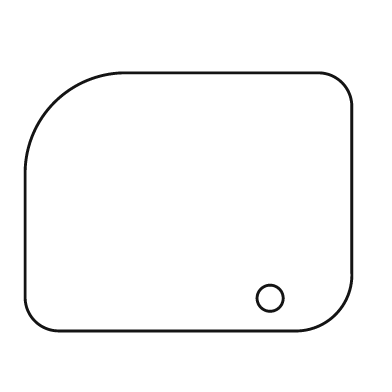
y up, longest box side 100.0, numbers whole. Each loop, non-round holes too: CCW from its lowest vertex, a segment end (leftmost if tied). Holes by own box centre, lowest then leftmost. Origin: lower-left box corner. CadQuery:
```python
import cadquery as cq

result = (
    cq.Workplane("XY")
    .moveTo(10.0, 0.0)
    .lineTo(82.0, 0.0)
    .threePointArc((95.0, 5.0), (100.0, 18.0))
    .lineTo(100.0, 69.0)
    .threePointArc((97.0, 76.0), (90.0, 79.0))
    .lineTo(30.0, 79.0)
    .threePointArc((9.0, 70.0), (0.0, 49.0))
    .lineTo(0.0, 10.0)
    .threePointArc((3.0, 3.0), (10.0, 0.0))
    .close()
    .moveTo(75.0, 10.0)
    .circle(4.0)
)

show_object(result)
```